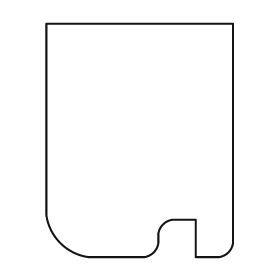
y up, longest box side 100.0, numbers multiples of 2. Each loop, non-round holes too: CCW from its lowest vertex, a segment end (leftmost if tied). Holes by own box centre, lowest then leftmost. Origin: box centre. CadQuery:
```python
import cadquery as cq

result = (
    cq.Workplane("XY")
    .moveTo(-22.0, -50.0)
    .lineTo(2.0, -50.0)
    .threePointArc((6.0, -48.0), (8.0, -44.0))
    .lineTo(8.0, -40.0)
    .threePointArc((10.0, -36.0), (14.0, -34.0))
    .lineTo(24.0, -34.0)
    .lineTo(24.0, -50.0)
    .lineTo(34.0, -50.0)
    .threePointArc((38.0, -48.0), (40.0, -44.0))
    .lineTo(40.0, 50.0)
    .lineTo(-40.0, 50.0)
    .lineTo(-40.0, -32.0)
    .threePointArc((-34.0, -44.0), (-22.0, -50.0))
    .close()
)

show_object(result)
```